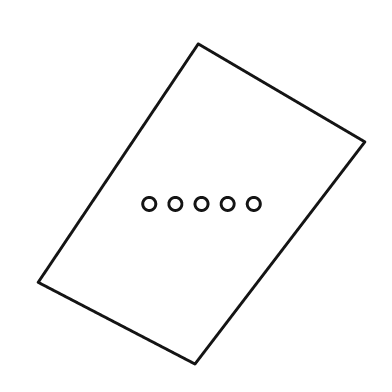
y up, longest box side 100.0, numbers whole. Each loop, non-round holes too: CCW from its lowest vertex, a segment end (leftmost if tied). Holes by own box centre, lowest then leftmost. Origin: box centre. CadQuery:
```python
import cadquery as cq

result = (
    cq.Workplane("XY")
    .moveTo(-2.0, -49.0)
    .lineTo(50.0, 19.0)
    .lineTo(-1.0, 49.0)
    .lineTo(-50.0, -24.0)
    .close()
    .moveTo(-16.0, 0.0)
    .circle(2.0)
    .moveTo(-8.0, 0.0)
    .circle(2.0)
    .moveTo(0.0, 0.0)
    .circle(2.0)
    .moveTo(8.0, 0.0)
    .circle(2.0)
    .moveTo(16.0, 0.0)
    .circle(2.0)
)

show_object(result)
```